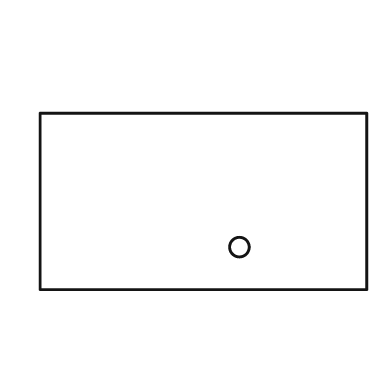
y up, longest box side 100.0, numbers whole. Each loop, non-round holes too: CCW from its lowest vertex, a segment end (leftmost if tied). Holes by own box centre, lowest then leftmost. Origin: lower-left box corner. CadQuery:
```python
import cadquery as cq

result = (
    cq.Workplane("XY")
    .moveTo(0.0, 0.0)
    .lineTo(100.0, 0.0)
    .lineTo(100.0, 54.0)
    .lineTo(0.0, 54.0)
    .close()
    .moveTo(61.0, 13.0)
    .circle(3.0)
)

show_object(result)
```